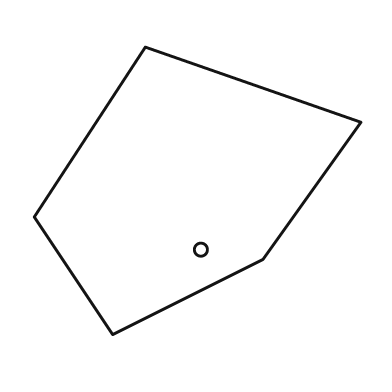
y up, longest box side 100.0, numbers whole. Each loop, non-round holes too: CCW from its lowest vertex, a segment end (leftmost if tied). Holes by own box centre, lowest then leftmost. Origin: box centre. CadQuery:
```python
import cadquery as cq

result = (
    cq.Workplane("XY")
    .moveTo(-26.0, -44.0)
    .lineTo(20.0, -21.0)
    .lineTo(50.0, 21.0)
    .lineTo(-16.0, 44.0)
    .lineTo(-50.0, -8.0)
    .close()
    .moveTo(1.0, -18.0)
    .circle(2.0)
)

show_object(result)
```